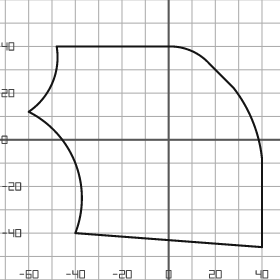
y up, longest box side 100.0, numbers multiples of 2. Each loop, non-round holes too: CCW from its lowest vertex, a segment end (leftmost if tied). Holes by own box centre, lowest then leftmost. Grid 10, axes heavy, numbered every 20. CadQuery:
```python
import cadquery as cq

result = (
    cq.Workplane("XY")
    .moveTo(40.0, -46.0)
    .lineTo(40.0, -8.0)
    .threePointArc((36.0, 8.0), (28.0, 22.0))
    .lineTo(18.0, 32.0)
    .threePointArc((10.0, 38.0), (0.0, 40.0))
    .lineTo(-48.0, 40.0)
    .threePointArc((-50.0, 24.0), (-60.0, 12.0))
    .threePointArc((-40.0, -10.0), (-40.0, -40.0))
    .close()
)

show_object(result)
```